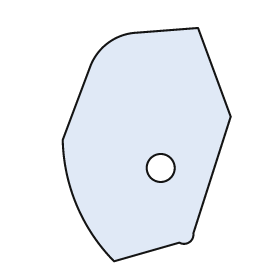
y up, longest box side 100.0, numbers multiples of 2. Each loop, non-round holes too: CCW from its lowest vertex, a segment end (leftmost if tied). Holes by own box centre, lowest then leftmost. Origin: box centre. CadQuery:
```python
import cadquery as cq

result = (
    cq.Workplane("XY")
    .moveTo(-14.0, -50.0)
    .lineTo(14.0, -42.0)
    .threePointArc((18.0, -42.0), (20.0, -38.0))
    .lineTo(36.0, 12.0)
    .lineTo(22.0, 50.0)
    .lineTo(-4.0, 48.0)
    .threePointArc((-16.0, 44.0), (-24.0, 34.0))
    .lineTo(-36.0, 2.0)
    .threePointArc((-30.0, -26.0), (-14.0, -50.0))
    .close()
    .moveTo(6.0, -10.0)
    .circle(6.0)
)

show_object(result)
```